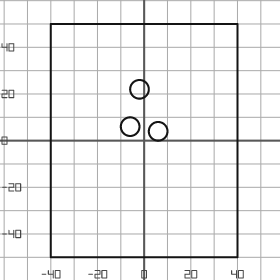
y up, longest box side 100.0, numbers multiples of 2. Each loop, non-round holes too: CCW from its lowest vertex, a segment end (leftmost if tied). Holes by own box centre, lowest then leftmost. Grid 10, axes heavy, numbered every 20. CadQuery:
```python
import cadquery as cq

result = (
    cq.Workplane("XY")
    .moveTo(-40.0, -50.0)
    .lineTo(40.0, -50.0)
    .lineTo(40.0, 50.0)
    .lineTo(-40.0, 50.0)
    .close()
    .moveTo(6.0, 4.0)
    .circle(4.0)
    .moveTo(-6.0, 6.0)
    .circle(4.0)
    .moveTo(-2.0, 22.0)
    .circle(4.0)
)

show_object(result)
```